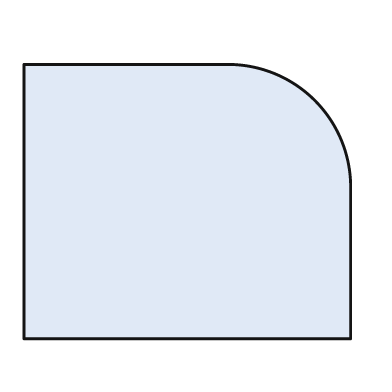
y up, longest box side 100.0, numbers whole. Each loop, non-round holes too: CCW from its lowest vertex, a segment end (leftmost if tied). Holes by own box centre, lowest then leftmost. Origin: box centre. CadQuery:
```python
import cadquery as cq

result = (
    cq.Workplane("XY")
    .moveTo(-50.0, -42.0)
    .lineTo(50.0, -42.0)
    .lineTo(50.0, 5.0)
    .threePointArc((39.0, 31.0), (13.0, 42.0))
    .lineTo(-50.0, 42.0)
    .close()
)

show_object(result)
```